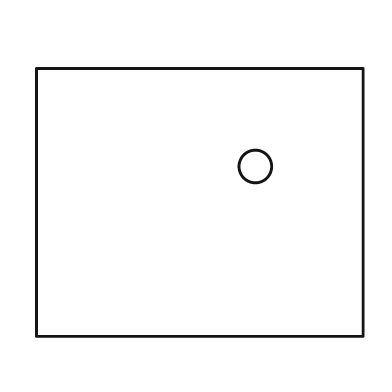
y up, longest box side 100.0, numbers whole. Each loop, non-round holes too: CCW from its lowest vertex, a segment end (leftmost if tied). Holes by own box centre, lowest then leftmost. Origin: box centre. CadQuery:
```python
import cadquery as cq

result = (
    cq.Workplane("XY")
    .moveTo(-50.0, -41.0)
    .lineTo(50.0, -41.0)
    .lineTo(50.0, 41.0)
    .lineTo(-50.0, 41.0)
    .close()
    .moveTo(17.0, 11.0)
    .circle(5.0)
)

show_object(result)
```